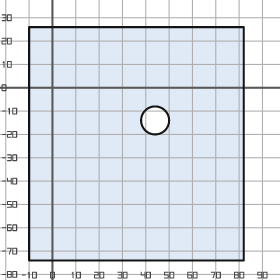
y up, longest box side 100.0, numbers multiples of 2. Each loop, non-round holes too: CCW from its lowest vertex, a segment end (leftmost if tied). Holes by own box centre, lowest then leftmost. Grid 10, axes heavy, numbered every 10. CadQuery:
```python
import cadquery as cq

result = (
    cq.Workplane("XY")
    .moveTo(-10.0, -74.0)
    .lineTo(82.0, -74.0)
    .lineTo(82.0, 26.0)
    .lineTo(-10.0, 26.0)
    .close()
    .moveTo(44.0, -14.0)
    .circle(6.0)
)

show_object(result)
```